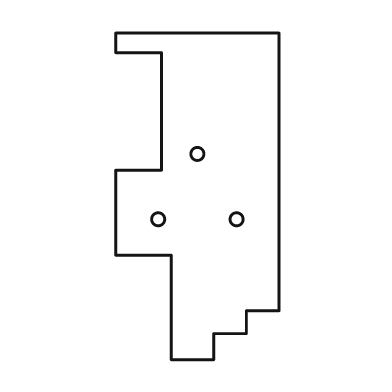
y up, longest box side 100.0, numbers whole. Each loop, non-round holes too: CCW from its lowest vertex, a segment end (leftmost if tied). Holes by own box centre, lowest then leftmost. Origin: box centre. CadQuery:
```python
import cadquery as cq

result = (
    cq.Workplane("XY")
    .moveTo(-8.0, -50.0)
    .lineTo(5.0, -50.0)
    .lineTo(5.0, -42.0)
    .lineTo(15.0, -42.0)
    .lineTo(15.0, -35.0)
    .lineTo(25.0, -35.0)
    .lineTo(25.0, 50.0)
    .lineTo(-25.0, 50.0)
    .lineTo(-25.0, 44.0)
    .lineTo(-11.0, 44.0)
    .lineTo(-11.0, 8.0)
    .lineTo(-25.0, 8.0)
    .lineTo(-25.0, -18.0)
    .lineTo(-8.0, -18.0)
    .close()
    .moveTo(-12.0, -7.0)
    .circle(2.0)
    .moveTo(12.0, -7.0)
    .circle(2.0)
    .moveTo(0.0, 13.0)
    .circle(2.0)
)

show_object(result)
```